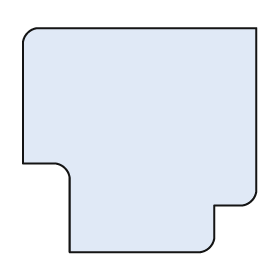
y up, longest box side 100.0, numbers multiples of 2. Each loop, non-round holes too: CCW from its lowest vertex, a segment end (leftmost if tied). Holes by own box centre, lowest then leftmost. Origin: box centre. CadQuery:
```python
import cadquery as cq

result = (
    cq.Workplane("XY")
    .moveTo(-30.0, -48.0)
    .lineTo(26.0, -48.0)
    .threePointArc((30.0, -46.0), (32.0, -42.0))
    .lineTo(32.0, -28.0)
    .lineTo(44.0, -28.0)
    .threePointArc((48.0, -26.0), (50.0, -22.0))
    .lineTo(50.0, 48.0)
    .lineTo(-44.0, 48.0)
    .threePointArc((-48.0, 46.0), (-50.0, 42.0))
    .lineTo(-50.0, -10.0)
    .lineTo(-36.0, -10.0)
    .threePointArc((-32.0, -12.0), (-30.0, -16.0))
    .close()
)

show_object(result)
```